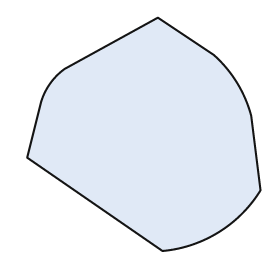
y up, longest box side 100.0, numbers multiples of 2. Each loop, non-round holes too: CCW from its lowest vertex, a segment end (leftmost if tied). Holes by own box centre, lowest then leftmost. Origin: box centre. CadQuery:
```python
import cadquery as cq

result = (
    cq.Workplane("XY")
    .moveTo(8.0, -50.0)
    .threePointArc((32.0, -42.0), (50.0, -24.0))
    .lineTo(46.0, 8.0)
    .threePointArc((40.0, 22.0), (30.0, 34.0))
    .lineTo(6.0, 50.0)
    .lineTo(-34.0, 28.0)
    .threePointArc((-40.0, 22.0), (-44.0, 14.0))
    .lineTo(-50.0, -10.0)
    .close()
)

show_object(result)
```